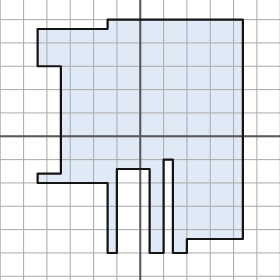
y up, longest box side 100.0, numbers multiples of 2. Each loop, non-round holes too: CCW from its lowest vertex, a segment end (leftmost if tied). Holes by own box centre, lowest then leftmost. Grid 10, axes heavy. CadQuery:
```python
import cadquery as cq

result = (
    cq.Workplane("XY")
    .moveTo(-14.0, -50.0)
    .lineTo(-10.0, -50.0)
    .lineTo(-10.0, -14.0)
    .lineTo(4.0, -14.0)
    .lineTo(4.0, -50.0)
    .lineTo(10.0, -50.0)
    .lineTo(10.0, -10.0)
    .lineTo(14.0, -10.0)
    .lineTo(14.0, -50.0)
    .lineTo(20.0, -50.0)
    .lineTo(20.0, -44.0)
    .lineTo(44.0, -44.0)
    .lineTo(44.0, 50.0)
    .lineTo(-14.0, 50.0)
    .lineTo(-14.0, 46.0)
    .lineTo(-44.0, 46.0)
    .lineTo(-44.0, 30.0)
    .lineTo(-34.0, 30.0)
    .lineTo(-34.0, -16.0)
    .lineTo(-44.0, -16.0)
    .lineTo(-44.0, -20.0)
    .lineTo(-14.0, -20.0)
    .close()
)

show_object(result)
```